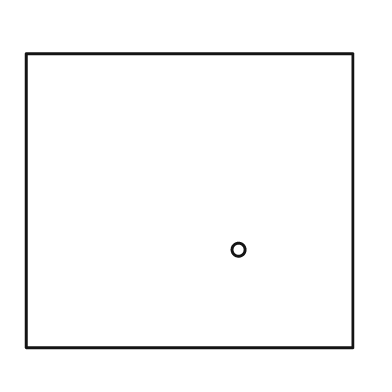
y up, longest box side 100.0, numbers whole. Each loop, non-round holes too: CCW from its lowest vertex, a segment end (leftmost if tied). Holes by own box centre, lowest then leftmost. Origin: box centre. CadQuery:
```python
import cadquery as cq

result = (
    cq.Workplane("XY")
    .moveTo(-50.0, -45.0)
    .lineTo(50.0, -45.0)
    .lineTo(50.0, 45.0)
    .lineTo(-50.0, 45.0)
    .close()
    .moveTo(15.0, -15.0)
    .circle(2.0)
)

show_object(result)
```